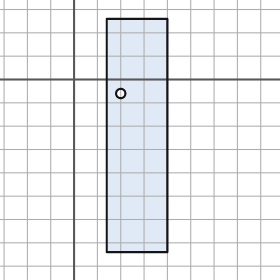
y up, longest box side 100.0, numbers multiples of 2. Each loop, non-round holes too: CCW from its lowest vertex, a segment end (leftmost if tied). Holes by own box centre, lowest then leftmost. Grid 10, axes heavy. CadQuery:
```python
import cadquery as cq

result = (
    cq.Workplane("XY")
    .moveTo(14.0, -74.0)
    .lineTo(40.0, -74.0)
    .lineTo(40.0, 26.0)
    .lineTo(14.0, 26.0)
    .close()
    .moveTo(20.0, -6.0)
    .circle(2.0)
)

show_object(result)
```